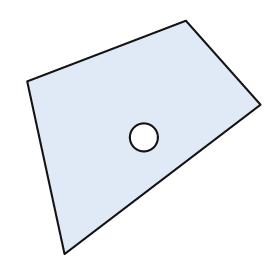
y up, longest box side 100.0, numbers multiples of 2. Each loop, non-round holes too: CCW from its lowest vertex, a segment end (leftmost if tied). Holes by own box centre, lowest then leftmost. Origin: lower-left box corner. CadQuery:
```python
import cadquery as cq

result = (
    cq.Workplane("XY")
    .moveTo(16.0, 0.0)
    .lineTo(100.0, 64.0)
    .lineTo(68.0, 100.0)
    .lineTo(0.0, 74.0)
    .close()
    .moveTo(50.0, 50.0)
    .circle(6.0)
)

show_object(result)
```